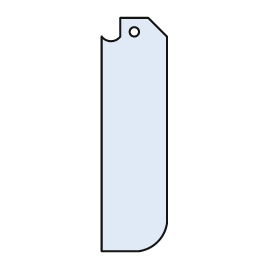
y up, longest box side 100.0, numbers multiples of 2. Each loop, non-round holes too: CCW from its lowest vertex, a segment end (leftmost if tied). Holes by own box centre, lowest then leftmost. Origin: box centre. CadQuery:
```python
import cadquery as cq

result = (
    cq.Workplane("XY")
    .moveTo(-14.0, -50.0)
    .lineTo(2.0, -50.0)
    .threePointArc((10.0, -46.0), (14.0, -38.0))
    .lineTo(14.0, 42.0)
    .lineTo(6.0, 50.0)
    .lineTo(-6.0, 50.0)
    .lineTo(-6.0, 42.0)
    .threePointArc((-10.0, 40.0), (-14.0, 42.0))
    .close()
    .moveTo(0.0, 44.0)
    .circle(2.0)
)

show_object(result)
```